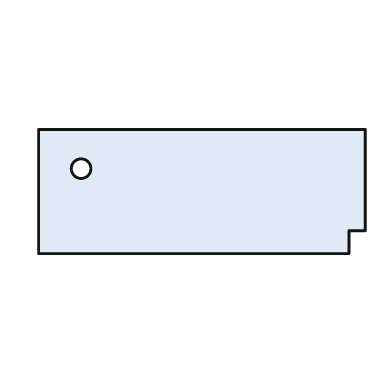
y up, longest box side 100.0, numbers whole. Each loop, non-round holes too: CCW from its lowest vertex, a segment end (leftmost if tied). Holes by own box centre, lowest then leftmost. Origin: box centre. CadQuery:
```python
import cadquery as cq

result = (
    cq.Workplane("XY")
    .moveTo(-50.0, -19.0)
    .lineTo(45.0, -19.0)
    .lineTo(45.0, -12.0)
    .lineTo(50.0, -12.0)
    .lineTo(50.0, 19.0)
    .lineTo(-50.0, 19.0)
    .close()
    .moveTo(-37.0, 7.0)
    .circle(3.0)
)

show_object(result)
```